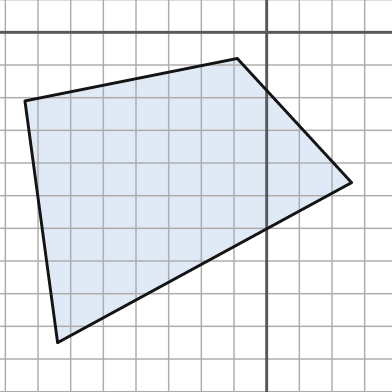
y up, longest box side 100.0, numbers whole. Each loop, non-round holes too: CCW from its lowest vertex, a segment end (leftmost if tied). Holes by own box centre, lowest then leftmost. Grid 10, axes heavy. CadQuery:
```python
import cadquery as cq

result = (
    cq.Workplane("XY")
    .moveTo(-64.0, -95.0)
    .lineTo(26.0, -46.0)
    .lineTo(-9.0, -8.0)
    .lineTo(-74.0, -21.0)
    .close()
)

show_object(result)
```